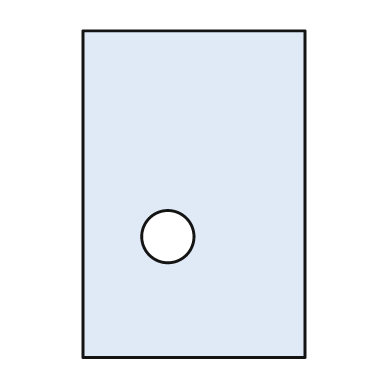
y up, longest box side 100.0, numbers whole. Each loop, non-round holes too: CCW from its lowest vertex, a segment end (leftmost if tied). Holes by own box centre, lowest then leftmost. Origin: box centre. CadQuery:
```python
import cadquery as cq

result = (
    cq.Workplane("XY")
    .moveTo(-34.0, -50.0)
    .lineTo(34.0, -50.0)
    .lineTo(34.0, 50.0)
    .lineTo(-34.0, 50.0)
    .close()
    .moveTo(-8.0, -13.0)
    .circle(8.0)
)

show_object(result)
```